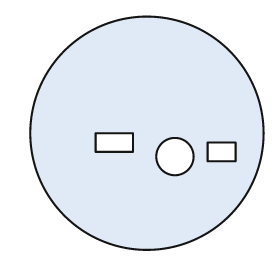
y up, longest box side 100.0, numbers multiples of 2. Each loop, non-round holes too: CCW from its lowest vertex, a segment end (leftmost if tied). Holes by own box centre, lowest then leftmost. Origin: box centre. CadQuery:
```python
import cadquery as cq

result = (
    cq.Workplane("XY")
    .moveTo(0.0, 0.0)
    .circle(50.0)
    .moveTo(12.0, -10.0)
    .circle(8.0)
    .moveTo(26.0, -12.0)
    .lineTo(38.0, -12.0)
    .lineTo(38.0, -4.0)
    .lineTo(26.0, -4.0)
    .close()
    .moveTo(-22.0, -8.0)
    .lineTo(-6.0, -8.0)
    .lineTo(-6.0, 0.0)
    .lineTo(-22.0, 0.0)
    .close()
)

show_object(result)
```